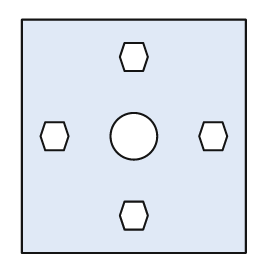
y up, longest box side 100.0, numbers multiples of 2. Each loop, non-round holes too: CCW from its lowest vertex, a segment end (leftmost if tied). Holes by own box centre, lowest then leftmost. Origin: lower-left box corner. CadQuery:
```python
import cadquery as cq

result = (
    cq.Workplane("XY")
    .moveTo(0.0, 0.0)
    .lineTo(96.0, 0.0)
    .lineTo(96.0, 100.0)
    .lineTo(0.0, 100.0)
    .close()
    .moveTo(44.0, 10.0)
    .lineTo(52.0, 10.0)
    .lineTo(54.0, 16.0)
    .lineTo(52.0, 22.0)
    .lineTo(44.0, 22.0)
    .lineTo(42.0, 16.0)
    .close()
    .moveTo(10.0, 44.0)
    .lineTo(18.0, 44.0)
    .lineTo(20.0, 50.0)
    .lineTo(18.0, 56.0)
    .lineTo(10.0, 56.0)
    .lineTo(8.0, 50.0)
    .close()
    .moveTo(48.0, 50.0)
    .circle(10.0)
    .moveTo(78.0, 44.0)
    .lineTo(86.0, 44.0)
    .lineTo(88.0, 50.0)
    .lineTo(86.0, 56.0)
    .lineTo(78.0, 56.0)
    .lineTo(76.0, 50.0)
    .close()
    .moveTo(44.0, 78.0)
    .lineTo(52.0, 78.0)
    .lineTo(54.0, 84.0)
    .lineTo(52.0, 90.0)
    .lineTo(44.0, 90.0)
    .lineTo(42.0, 84.0)
    .close()
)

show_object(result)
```